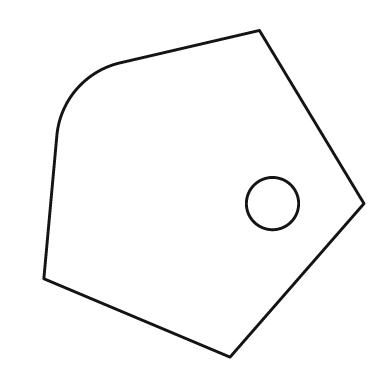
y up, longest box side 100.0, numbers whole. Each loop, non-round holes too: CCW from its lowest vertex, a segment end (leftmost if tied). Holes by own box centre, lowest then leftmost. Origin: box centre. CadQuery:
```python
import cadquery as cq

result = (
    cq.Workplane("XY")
    .moveTo(8.0, -50.0)
    .lineTo(49.0, -3.0)
    .lineTo(17.0, 50.0)
    .lineTo(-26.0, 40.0)
    .threePointArc((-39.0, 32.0), (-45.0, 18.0))
    .lineTo(-49.0, -26.0)
    .close()
    .moveTo(21.0, -3.0)
    .circle(8.0)
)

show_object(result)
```